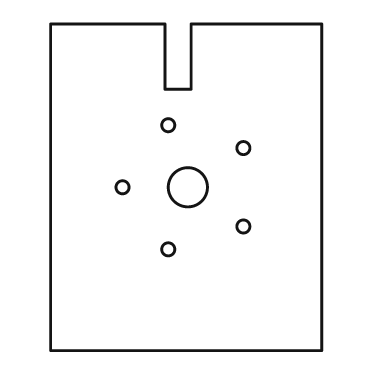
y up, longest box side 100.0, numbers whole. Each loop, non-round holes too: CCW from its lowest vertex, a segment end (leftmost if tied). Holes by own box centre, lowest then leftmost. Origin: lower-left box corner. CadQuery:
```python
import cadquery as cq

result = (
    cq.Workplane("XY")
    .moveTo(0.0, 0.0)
    .lineTo(83.0, 0.0)
    .lineTo(83.0, 100.0)
    .lineTo(43.0, 100.0)
    .lineTo(43.0, 80.0)
    .lineTo(35.0, 80.0)
    .lineTo(35.0, 100.0)
    .lineTo(0.0, 100.0)
    .close()
    .moveTo(36.0, 31.0)
    .circle(2.0)
    .moveTo(59.0, 38.0)
    .circle(2.0)
    .moveTo(22.0, 50.0)
    .circle(2.0)
    .moveTo(42.0, 50.0)
    .circle(6.0)
    .moveTo(59.0, 62.0)
    .circle(2.0)
    .moveTo(36.0, 69.0)
    .circle(2.0)
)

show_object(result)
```